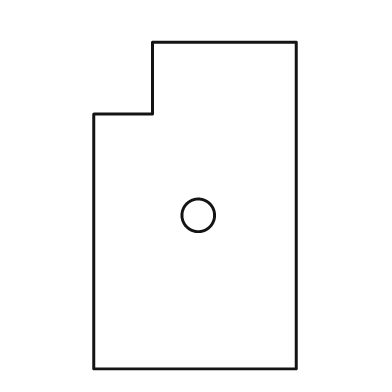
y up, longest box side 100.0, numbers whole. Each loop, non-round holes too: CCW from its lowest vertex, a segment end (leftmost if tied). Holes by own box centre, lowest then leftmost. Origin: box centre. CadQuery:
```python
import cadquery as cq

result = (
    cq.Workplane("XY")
    .moveTo(-31.0, -50.0)
    .lineTo(31.0, -50.0)
    .lineTo(31.0, 50.0)
    .lineTo(-13.0, 50.0)
    .lineTo(-13.0, 28.0)
    .lineTo(-31.0, 28.0)
    .close()
    .moveTo(1.0, -3.0)
    .circle(5.0)
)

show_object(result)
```